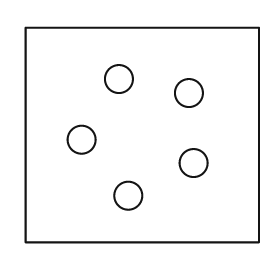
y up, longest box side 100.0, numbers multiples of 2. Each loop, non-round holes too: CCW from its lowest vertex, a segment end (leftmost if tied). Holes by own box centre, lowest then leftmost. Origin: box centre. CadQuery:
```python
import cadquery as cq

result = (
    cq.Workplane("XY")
    .moveTo(-50.0, -46.0)
    .lineTo(50.0, -46.0)
    .lineTo(50.0, 46.0)
    .lineTo(-50.0, 46.0)
    .close()
    .moveTo(-6.0, -26.0)
    .circle(6.0)
    .moveTo(22.0, -12.0)
    .circle(6.0)
    .moveTo(-26.0, -2.0)
    .circle(6.0)
    .moveTo(20.0, 18.0)
    .circle(6.0)
    .moveTo(-10.0, 24.0)
    .circle(6.0)
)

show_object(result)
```